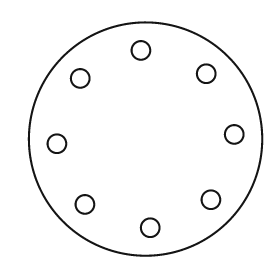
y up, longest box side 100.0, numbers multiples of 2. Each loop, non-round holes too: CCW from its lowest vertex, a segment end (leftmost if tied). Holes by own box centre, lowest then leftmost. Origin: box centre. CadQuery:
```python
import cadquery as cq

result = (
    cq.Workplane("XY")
    .moveTo(0.0, 0.0)
    .circle(50.0)
    .moveTo(2.0, -38.0)
    .circle(4.0)
    .moveTo(-26.0, -28.0)
    .circle(4.0)
    .moveTo(28.0, -26.0)
    .circle(4.0)
    .moveTo(-38.0, -2.0)
    .circle(4.0)
    .moveTo(38.0, 2.0)
    .circle(4.0)
    .moveTo(-28.0, 26.0)
    .circle(4.0)
    .moveTo(26.0, 28.0)
    .circle(4.0)
    .moveTo(-2.0, 38.0)
    .circle(4.0)
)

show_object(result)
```